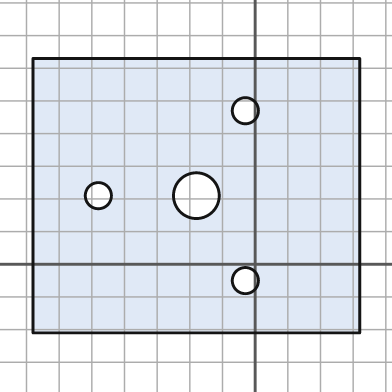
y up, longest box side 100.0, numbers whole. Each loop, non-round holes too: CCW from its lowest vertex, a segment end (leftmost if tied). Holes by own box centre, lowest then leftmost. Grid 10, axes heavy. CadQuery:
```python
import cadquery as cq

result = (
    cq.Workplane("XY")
    .moveTo(-68.0, -21.0)
    .lineTo(32.0, -21.0)
    .lineTo(32.0, 63.0)
    .lineTo(-68.0, 63.0)
    .close()
    .moveTo(-3.0, -5.0)
    .circle(4.0)
    .moveTo(-48.0, 21.0)
    .circle(4.0)
    .moveTo(-18.0, 21.0)
    .circle(7.0)
    .moveTo(-3.0, 47.0)
    .circle(4.0)
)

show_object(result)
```